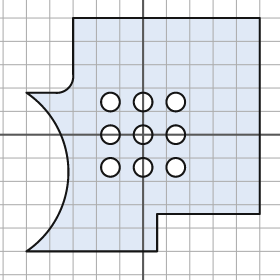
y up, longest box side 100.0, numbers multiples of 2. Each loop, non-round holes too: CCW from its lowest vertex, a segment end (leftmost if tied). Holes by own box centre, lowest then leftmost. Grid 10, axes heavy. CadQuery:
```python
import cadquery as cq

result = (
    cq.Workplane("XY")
    .moveTo(-50.0, -50.0)
    .lineTo(6.0, -50.0)
    .lineTo(6.0, -34.0)
    .lineTo(50.0, -34.0)
    .lineTo(50.0, 50.0)
    .lineTo(-30.0, 50.0)
    .lineTo(-30.0, 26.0)
    .threePointArc((-32.0, 20.0), (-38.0, 18.0))
    .lineTo(-50.0, 18.0)
    .threePointArc((-32.0, -16.0), (-50.0, -50.0))
    .close()
    .moveTo(-14.0, -14.0)
    .circle(4.0)
    .moveTo(0.0, -14.0)
    .circle(4.0)
    .moveTo(14.0, -14.0)
    .circle(4.0)
    .moveTo(-14.0, 0.0)
    .circle(4.0)
    .moveTo(0.0, 0.0)
    .circle(4.0)
    .moveTo(14.0, 0.0)
    .circle(4.0)
    .moveTo(-14.0, 14.0)
    .circle(4.0)
    .moveTo(0.0, 14.0)
    .circle(4.0)
    .moveTo(14.0, 14.0)
    .circle(4.0)
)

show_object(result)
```